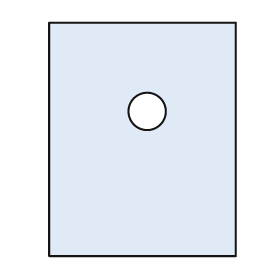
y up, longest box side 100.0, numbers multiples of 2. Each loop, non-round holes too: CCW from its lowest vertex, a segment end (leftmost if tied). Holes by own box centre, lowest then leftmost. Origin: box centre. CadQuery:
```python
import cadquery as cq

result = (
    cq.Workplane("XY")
    .moveTo(-40.0, -50.0)
    .lineTo(40.0, -50.0)
    .lineTo(40.0, 50.0)
    .lineTo(-40.0, 50.0)
    .close()
    .moveTo(2.0, 12.0)
    .circle(8.0)
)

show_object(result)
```